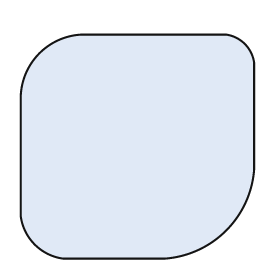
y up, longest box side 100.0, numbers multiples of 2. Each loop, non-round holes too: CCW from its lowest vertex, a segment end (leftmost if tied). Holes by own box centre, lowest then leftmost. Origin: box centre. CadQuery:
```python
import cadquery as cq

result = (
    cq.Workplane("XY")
    .moveTo(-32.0, -48.0)
    .lineTo(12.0, -48.0)
    .threePointArc((38.0, -36.0), (50.0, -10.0))
    .lineTo(50.0, 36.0)
    .threePointArc((46.0, 44.0), (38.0, 48.0))
    .lineTo(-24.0, 48.0)
    .threePointArc((-42.0, 40.0), (-50.0, 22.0))
    .lineTo(-50.0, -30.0)
    .threePointArc((-44.0, -42.0), (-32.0, -48.0))
    .close()
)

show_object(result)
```